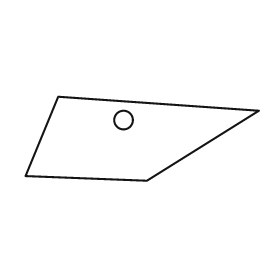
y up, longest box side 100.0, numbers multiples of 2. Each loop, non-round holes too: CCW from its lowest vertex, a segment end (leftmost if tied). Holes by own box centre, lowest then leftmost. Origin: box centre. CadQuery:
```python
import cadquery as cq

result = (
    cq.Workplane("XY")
    .moveTo(2.0, -18.0)
    .lineTo(50.0, 12.0)
    .lineTo(-36.0, 18.0)
    .lineTo(-50.0, -16.0)
    .close()
    .moveTo(-8.0, 8.0)
    .circle(4.0)
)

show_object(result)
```